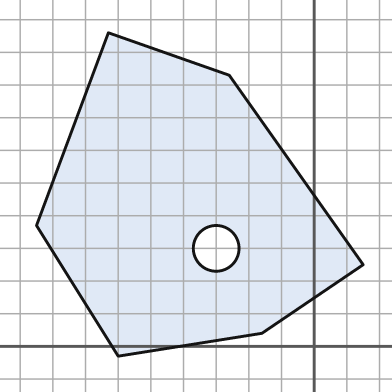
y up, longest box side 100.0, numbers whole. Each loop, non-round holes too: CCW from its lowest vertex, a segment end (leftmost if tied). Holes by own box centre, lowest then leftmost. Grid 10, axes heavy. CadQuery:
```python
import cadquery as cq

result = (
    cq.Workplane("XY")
    .moveTo(-60.0, -3.0)
    .lineTo(-16.0, 4.0)
    .lineTo(15.0, 25.0)
    .lineTo(-26.0, 83.0)
    .lineTo(-63.0, 96.0)
    .lineTo(-85.0, 37.0)
    .close()
    .moveTo(-30.0, 30.0)
    .circle(7.0)
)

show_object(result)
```